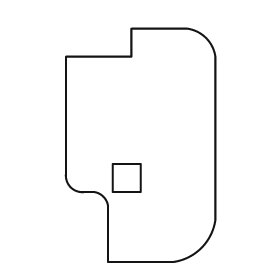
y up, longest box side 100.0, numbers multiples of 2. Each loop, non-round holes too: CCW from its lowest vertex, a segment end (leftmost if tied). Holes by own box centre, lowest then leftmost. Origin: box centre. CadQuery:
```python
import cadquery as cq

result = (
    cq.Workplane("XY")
    .moveTo(-14.0, -50.0)
    .lineTo(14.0, -50.0)
    .threePointArc((26.0, -44.0), (32.0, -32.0))
    .lineTo(32.0, 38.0)
    .threePointArc((28.0, 46.0), (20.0, 50.0))
    .lineTo(-4.0, 50.0)
    .lineTo(-4.0, 38.0)
    .lineTo(-32.0, 38.0)
    .lineTo(-32.0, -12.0)
    .threePointArc((-30.0, -18.0), (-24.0, -20.0))
    .lineTo(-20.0, -20.0)
    .threePointArc((-16.0, -22.0), (-14.0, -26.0))
    .close()
    .moveTo(-12.0, -20.0)
    .lineTo(0.0, -20.0)
    .lineTo(0.0, -8.0)
    .lineTo(-12.0, -8.0)
    .close()
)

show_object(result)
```